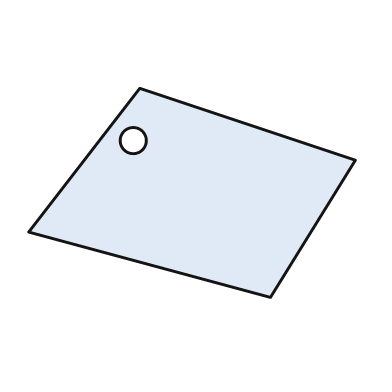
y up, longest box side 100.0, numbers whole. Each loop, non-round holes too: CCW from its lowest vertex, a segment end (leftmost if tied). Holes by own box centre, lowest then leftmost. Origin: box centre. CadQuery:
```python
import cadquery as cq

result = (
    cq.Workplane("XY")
    .moveTo(24.0, -32.0)
    .lineTo(50.0, 10.0)
    .lineTo(-16.0, 32.0)
    .lineTo(-50.0, -12.0)
    .close()
    .moveTo(-18.0, 16.0)
    .circle(4.0)
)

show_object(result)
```